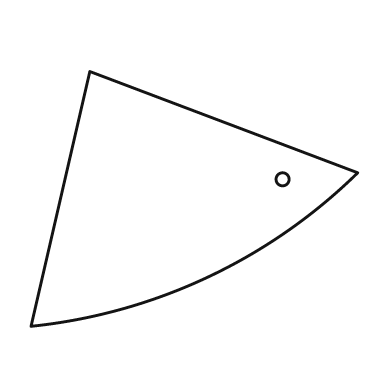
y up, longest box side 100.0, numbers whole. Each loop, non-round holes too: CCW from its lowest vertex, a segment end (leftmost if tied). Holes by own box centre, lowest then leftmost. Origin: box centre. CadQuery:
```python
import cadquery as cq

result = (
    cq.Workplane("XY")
    .moveTo(-50.0, -39.0)
    .threePointArc((4.0, -24.0), (50.0, 8.0))
    .lineTo(-32.0, 39.0)
    .close()
    .moveTo(27.0, 6.0)
    .circle(2.0)
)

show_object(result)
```